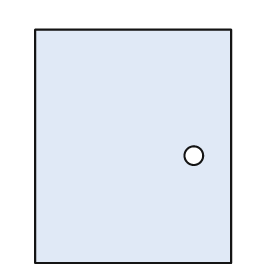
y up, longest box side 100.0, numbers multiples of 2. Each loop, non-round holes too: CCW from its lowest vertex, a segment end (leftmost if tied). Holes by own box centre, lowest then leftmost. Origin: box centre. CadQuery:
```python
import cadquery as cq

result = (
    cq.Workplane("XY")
    .moveTo(-42.0, -50.0)
    .lineTo(42.0, -50.0)
    .lineTo(42.0, 50.0)
    .lineTo(-42.0, 50.0)
    .close()
    .moveTo(26.0, -4.0)
    .circle(4.0)
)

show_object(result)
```